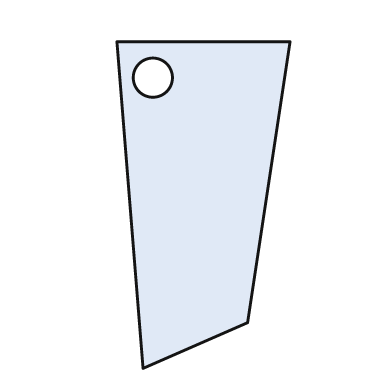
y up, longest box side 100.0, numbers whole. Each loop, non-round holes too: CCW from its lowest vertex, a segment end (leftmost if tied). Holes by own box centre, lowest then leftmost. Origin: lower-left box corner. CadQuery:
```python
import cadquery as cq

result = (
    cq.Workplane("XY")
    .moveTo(8.0, 0.0)
    .lineTo(40.0, 14.0)
    .lineTo(53.0, 100.0)
    .lineTo(0.0, 100.0)
    .close()
    .moveTo(11.0, 89.0)
    .circle(6.0)
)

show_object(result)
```